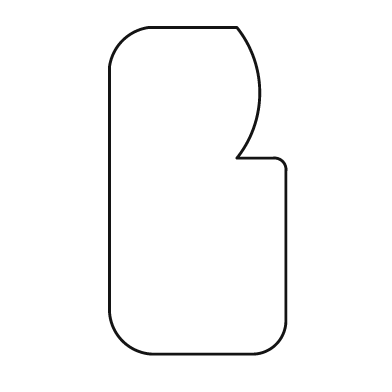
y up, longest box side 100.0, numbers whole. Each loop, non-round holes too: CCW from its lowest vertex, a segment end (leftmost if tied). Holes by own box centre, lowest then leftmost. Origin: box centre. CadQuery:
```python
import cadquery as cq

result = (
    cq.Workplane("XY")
    .moveTo(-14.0, -50.0)
    .lineTo(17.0, -50.0)
    .threePointArc((24.0, -47.0), (27.0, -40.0))
    .lineTo(27.0, 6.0)
    .threePointArc((26.0, 9.0), (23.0, 10.0))
    .lineTo(12.0, 10.0)
    .threePointArc((19.0, 30.0), (12.0, 50.0))
    .lineTo(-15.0, 50.0)
    .threePointArc((-23.0, 46.0), (-27.0, 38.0))
    .lineTo(-27.0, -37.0)
    .threePointArc((-23.0, -46.0), (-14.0, -50.0))
    .close()
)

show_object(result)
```